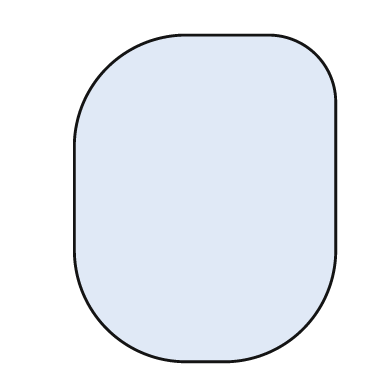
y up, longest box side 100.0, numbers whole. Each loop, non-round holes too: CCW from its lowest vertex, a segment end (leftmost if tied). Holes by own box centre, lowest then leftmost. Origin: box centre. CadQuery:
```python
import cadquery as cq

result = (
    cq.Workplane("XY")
    .moveTo(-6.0, -50.0)
    .lineTo(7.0, -50.0)
    .threePointArc((30.0, -40.0), (40.0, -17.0))
    .lineTo(40.0, 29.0)
    .threePointArc((34.0, 44.0), (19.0, 50.0))
    .lineTo(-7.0, 50.0)
    .threePointArc((-30.0, 40.0), (-40.0, 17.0))
    .lineTo(-40.0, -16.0)
    .threePointArc((-30.0, -40.0), (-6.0, -50.0))
    .close()
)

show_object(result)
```